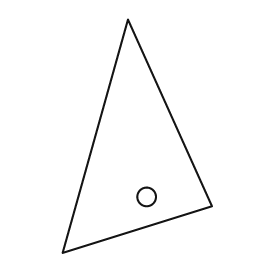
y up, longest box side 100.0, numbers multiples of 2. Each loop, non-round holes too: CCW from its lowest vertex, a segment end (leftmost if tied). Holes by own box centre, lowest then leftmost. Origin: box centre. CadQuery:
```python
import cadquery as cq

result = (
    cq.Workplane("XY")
    .moveTo(-32.0, -50.0)
    .lineTo(32.0, -30.0)
    .lineTo(-4.0, 50.0)
    .close()
    .moveTo(4.0, -26.0)
    .circle(4.0)
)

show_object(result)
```